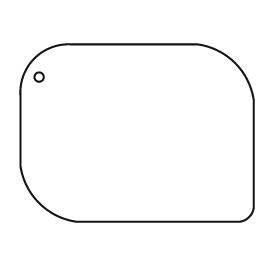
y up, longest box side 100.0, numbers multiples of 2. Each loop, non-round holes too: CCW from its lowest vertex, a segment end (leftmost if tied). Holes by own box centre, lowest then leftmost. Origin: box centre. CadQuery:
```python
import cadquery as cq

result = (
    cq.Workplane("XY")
    .moveTo(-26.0, -38.0)
    .lineTo(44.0, -38.0)
    .threePointArc((48.0, -36.0), (50.0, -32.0))
    .lineTo(50.0, 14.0)
    .threePointArc((42.0, 30.0), (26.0, 38.0))
    .lineTo(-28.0, 38.0)
    .threePointArc((-44.0, 32.0), (-50.0, 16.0))
    .lineTo(-50.0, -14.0)
    .threePointArc((-42.0, -30.0), (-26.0, -38.0))
    .close()
    .moveTo(-42.0, 24.0)
    .circle(2.0)
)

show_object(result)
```